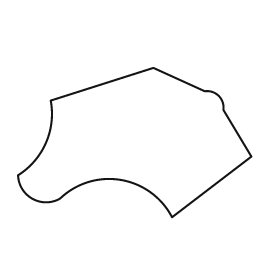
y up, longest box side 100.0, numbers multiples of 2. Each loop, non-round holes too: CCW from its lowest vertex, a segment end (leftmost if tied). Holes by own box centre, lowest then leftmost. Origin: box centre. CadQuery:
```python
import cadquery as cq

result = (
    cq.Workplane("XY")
    .moveTo(16.0, -32.0)
    .lineTo(50.0, -6.0)
    .lineTo(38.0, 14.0)
    .threePointArc((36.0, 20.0), (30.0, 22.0))
    .lineTo(8.0, 32.0)
    .lineTo(-36.0, 18.0)
    .threePointArc((-38.0, 0.0), (-50.0, -14.0))
    .threePointArc((-44.0, -24.0), (-32.0, -24.0))
    .threePointArc((-6.0, -16.0), (16.0, -32.0))
    .close()
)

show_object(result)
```